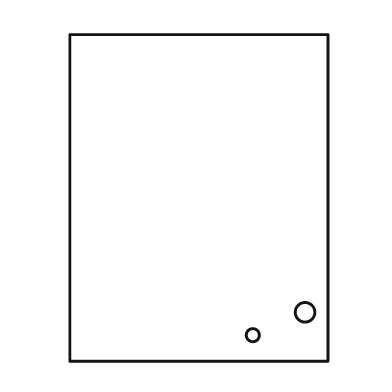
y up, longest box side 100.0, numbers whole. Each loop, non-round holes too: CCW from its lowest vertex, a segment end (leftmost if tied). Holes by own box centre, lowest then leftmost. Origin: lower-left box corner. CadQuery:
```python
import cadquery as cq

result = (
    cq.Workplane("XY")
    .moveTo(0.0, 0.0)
    .lineTo(79.0, 0.0)
    .lineTo(79.0, 100.0)
    .lineTo(0.0, 100.0)
    .close()
    .moveTo(56.0, 8.0)
    .circle(2.0)
    .moveTo(72.0, 15.0)
    .circle(3.0)
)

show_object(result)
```